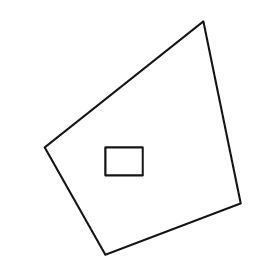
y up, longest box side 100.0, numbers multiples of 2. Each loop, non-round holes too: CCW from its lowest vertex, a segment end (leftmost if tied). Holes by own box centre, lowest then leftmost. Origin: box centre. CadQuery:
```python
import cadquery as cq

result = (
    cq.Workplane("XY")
    .moveTo(-16.0, -50.0)
    .lineTo(42.0, -28.0)
    .lineTo(26.0, 50.0)
    .lineTo(-42.0, -4.0)
    .close()
    .moveTo(-16.0, -16.0)
    .lineTo(0.0, -16.0)
    .lineTo(0.0, -4.0)
    .lineTo(-16.0, -4.0)
    .close()
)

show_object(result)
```